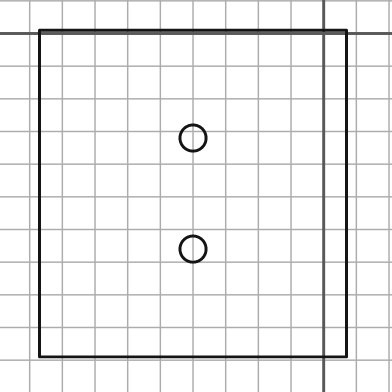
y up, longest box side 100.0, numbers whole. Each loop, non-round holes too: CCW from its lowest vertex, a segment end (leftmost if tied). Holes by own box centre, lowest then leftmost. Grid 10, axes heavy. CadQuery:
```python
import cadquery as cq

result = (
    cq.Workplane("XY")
    .moveTo(-87.0, -99.0)
    .lineTo(7.0, -99.0)
    .lineTo(7.0, 1.0)
    .lineTo(-87.0, 1.0)
    .close()
    .moveTo(-40.0, -66.0)
    .circle(4.0)
    .moveTo(-40.0, -32.0)
    .circle(4.0)
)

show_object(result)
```